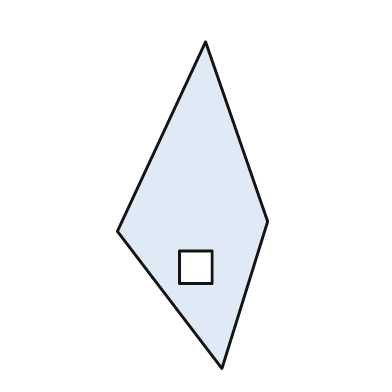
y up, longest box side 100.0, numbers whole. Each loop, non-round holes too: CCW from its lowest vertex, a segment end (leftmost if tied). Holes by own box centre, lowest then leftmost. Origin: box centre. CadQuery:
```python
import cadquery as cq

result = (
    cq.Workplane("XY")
    .moveTo(9.0, -50.0)
    .lineTo(23.0, -5.0)
    .lineTo(4.0, 50.0)
    .lineTo(-23.0, -8.0)
    .close()
    .moveTo(-4.0, -24.0)
    .lineTo(6.0, -24.0)
    .lineTo(6.0, -14.0)
    .lineTo(-4.0, -14.0)
    .close()
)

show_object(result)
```